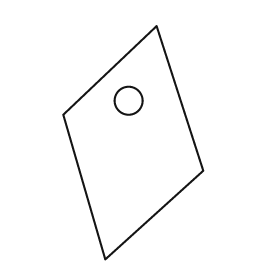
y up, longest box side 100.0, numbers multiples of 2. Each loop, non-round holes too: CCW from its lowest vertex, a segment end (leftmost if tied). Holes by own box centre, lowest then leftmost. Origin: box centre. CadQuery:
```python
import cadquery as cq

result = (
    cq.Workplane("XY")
    .moveTo(-12.0, -50.0)
    .lineTo(30.0, -12.0)
    .lineTo(10.0, 50.0)
    .lineTo(-30.0, 12.0)
    .close()
    .moveTo(-2.0, 18.0)
    .circle(6.0)
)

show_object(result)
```